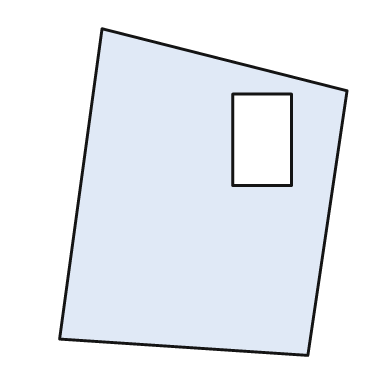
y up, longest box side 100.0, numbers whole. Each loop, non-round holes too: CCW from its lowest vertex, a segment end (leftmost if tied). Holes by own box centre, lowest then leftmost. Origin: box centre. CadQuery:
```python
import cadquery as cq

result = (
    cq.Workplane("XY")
    .moveTo(32.0, -50.0)
    .lineTo(44.0, 31.0)
    .lineTo(-31.0, 50.0)
    .lineTo(-44.0, -45.0)
    .close()
    .moveTo(9.0, 2.0)
    .lineTo(27.0, 2.0)
    .lineTo(27.0, 30.0)
    .lineTo(9.0, 30.0)
    .close()
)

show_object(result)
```